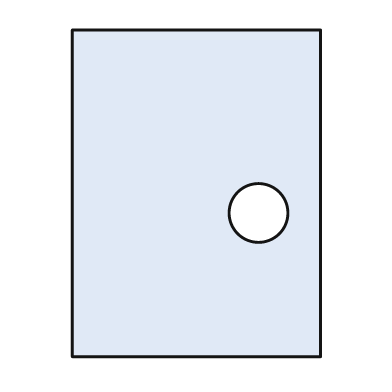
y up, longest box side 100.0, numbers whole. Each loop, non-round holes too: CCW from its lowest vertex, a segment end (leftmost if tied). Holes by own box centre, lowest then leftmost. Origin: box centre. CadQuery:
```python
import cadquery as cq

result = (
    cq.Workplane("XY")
    .moveTo(-38.0, -50.0)
    .lineTo(38.0, -50.0)
    .lineTo(38.0, 50.0)
    .lineTo(-38.0, 50.0)
    .close()
    .moveTo(19.0, -6.0)
    .circle(9.0)
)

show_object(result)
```